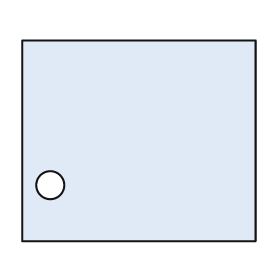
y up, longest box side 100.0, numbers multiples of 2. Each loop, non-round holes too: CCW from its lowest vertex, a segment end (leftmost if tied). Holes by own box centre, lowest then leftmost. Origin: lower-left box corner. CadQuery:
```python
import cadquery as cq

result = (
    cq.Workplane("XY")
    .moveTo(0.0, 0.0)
    .lineTo(100.0, 0.0)
    .lineTo(100.0, 86.0)
    .lineTo(0.0, 86.0)
    .close()
    .moveTo(12.0, 24.0)
    .circle(6.0)
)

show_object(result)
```